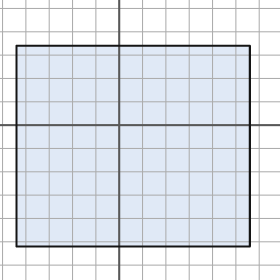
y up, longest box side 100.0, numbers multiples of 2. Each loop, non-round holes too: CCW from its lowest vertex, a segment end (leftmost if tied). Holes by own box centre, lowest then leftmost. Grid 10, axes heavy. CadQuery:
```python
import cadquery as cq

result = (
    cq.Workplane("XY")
    .moveTo(-44.0, -52.0)
    .lineTo(56.0, -52.0)
    .lineTo(56.0, 34.0)
    .lineTo(-44.0, 34.0)
    .close()
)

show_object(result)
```